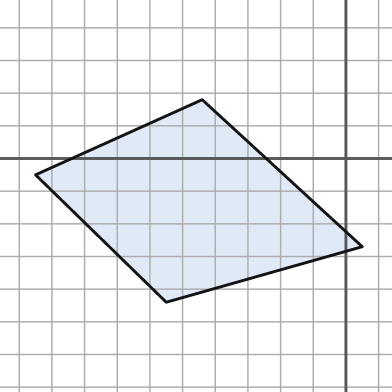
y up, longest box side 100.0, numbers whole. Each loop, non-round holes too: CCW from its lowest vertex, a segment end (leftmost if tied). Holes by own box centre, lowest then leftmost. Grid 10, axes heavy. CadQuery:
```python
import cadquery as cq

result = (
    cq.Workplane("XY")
    .moveTo(-55.0, -44.0)
    .lineTo(5.0, -27.0)
    .lineTo(-44.0, 18.0)
    .lineTo(-95.0, -5.0)
    .close()
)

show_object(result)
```